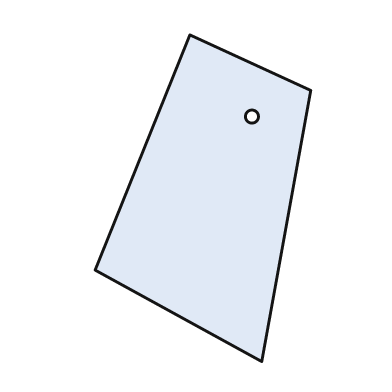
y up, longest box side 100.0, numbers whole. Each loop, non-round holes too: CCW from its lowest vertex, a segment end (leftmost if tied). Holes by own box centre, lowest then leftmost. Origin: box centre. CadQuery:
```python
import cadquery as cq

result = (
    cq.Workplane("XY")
    .moveTo(18.0, -50.0)
    .lineTo(33.0, 33.0)
    .lineTo(-4.0, 50.0)
    .lineTo(-33.0, -22.0)
    .close()
    .moveTo(15.0, 25.0)
    .circle(2.0)
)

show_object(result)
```